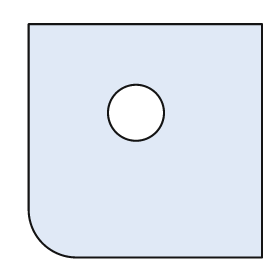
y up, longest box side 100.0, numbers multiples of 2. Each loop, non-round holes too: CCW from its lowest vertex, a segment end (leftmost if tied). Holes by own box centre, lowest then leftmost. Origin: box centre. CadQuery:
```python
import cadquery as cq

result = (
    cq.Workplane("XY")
    .moveTo(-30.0, -50.0)
    .lineTo(50.0, -50.0)
    .lineTo(50.0, 50.0)
    .lineTo(-50.0, 50.0)
    .lineTo(-50.0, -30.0)
    .threePointArc((-44.0, -44.0), (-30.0, -50.0))
    .close()
    .moveTo(-4.0, 12.0)
    .circle(12.0)
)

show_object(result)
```